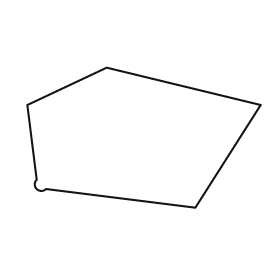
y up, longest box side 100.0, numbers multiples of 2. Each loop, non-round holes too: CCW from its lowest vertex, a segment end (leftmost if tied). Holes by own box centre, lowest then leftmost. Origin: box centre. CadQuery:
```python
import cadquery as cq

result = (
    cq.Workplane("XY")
    .moveTo(22.0, -30.0)
    .lineTo(50.0, 14.0)
    .lineTo(-16.0, 30.0)
    .lineTo(-50.0, 14.0)
    .lineTo(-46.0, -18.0)
    .threePointArc((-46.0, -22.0), (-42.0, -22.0))
    .close()
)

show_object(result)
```